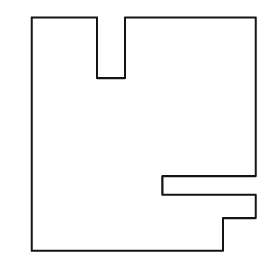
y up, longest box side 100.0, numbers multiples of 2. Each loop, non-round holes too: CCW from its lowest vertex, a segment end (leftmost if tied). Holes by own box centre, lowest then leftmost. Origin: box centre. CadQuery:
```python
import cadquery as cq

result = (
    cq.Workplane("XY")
    .moveTo(-48.0, -50.0)
    .lineTo(34.0, -50.0)
    .lineTo(34.0, -36.0)
    .lineTo(48.0, -36.0)
    .lineTo(48.0, -26.0)
    .lineTo(8.0, -26.0)
    .lineTo(8.0, -18.0)
    .lineTo(48.0, -18.0)
    .lineTo(48.0, 50.0)
    .lineTo(-8.0, 50.0)
    .lineTo(-8.0, 24.0)
    .lineTo(-20.0, 24.0)
    .lineTo(-20.0, 50.0)
    .lineTo(-48.0, 50.0)
    .close()
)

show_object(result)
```